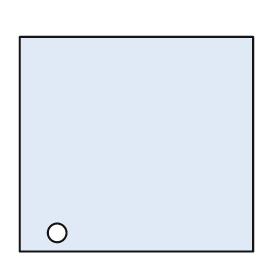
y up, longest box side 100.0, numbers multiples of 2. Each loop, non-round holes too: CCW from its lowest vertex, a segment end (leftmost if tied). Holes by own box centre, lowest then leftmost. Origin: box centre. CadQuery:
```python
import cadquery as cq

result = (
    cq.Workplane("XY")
    .moveTo(-50.0, -46.0)
    .lineTo(50.0, -46.0)
    .lineTo(50.0, 46.0)
    .lineTo(-50.0, 46.0)
    .close()
    .moveTo(-34.0, -38.0)
    .circle(4.0)
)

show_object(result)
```